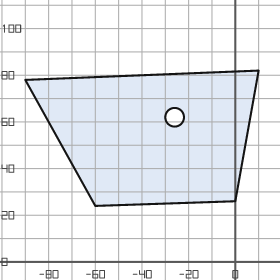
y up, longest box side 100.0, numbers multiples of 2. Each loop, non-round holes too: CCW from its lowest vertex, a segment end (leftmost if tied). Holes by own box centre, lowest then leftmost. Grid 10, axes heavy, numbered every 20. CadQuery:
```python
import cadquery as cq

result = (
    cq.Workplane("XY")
    .moveTo(-60.0, 24.0)
    .lineTo(0.0, 26.0)
    .lineTo(10.0, 82.0)
    .lineTo(-90.0, 78.0)
    .close()
    .moveTo(-26.0, 62.0)
    .circle(4.0)
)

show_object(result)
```